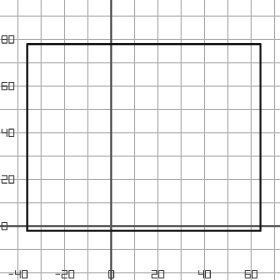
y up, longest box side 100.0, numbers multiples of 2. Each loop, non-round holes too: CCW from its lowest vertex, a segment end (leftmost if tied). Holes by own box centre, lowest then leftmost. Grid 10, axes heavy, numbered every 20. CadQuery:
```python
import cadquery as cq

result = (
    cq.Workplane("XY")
    .moveTo(-36.0, -2.0)
    .lineTo(64.0, -2.0)
    .lineTo(64.0, 78.0)
    .lineTo(-36.0, 78.0)
    .close()
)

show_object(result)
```